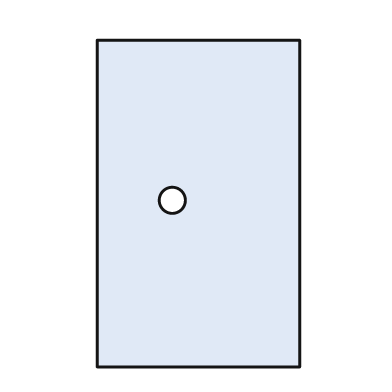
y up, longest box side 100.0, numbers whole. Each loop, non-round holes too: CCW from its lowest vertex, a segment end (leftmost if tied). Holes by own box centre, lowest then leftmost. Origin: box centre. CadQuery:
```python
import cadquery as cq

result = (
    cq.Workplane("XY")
    .moveTo(-31.0, -50.0)
    .lineTo(31.0, -50.0)
    .lineTo(31.0, 50.0)
    .lineTo(-31.0, 50.0)
    .close()
    .moveTo(-8.0, 1.0)
    .circle(4.0)
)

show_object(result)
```